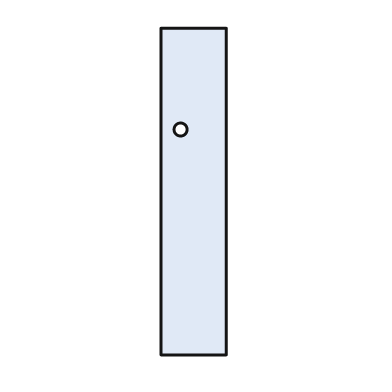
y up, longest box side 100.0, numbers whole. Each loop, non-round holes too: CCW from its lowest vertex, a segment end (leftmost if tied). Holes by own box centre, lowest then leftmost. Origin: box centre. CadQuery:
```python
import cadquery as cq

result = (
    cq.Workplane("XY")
    .moveTo(-10.0, -50.0)
    .lineTo(10.0, -50.0)
    .lineTo(10.0, 50.0)
    .lineTo(-10.0, 50.0)
    .close()
    .moveTo(-4.0, 19.0)
    .circle(2.0)
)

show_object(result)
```